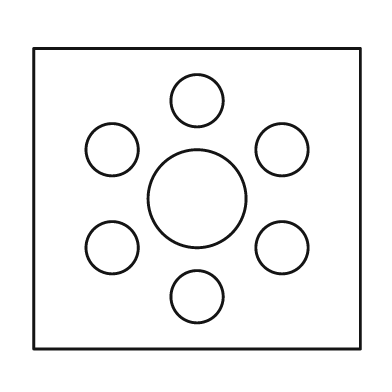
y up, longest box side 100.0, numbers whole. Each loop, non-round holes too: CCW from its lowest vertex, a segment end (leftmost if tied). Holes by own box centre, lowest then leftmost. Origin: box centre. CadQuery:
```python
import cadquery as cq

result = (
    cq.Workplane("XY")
    .moveTo(-50.0, -46.0)
    .lineTo(50.0, -46.0)
    .lineTo(50.0, 46.0)
    .lineTo(-50.0, 46.0)
    .close()
    .moveTo(0.0, -30.0)
    .circle(8.0)
    .moveTo(-26.0, -15.0)
    .circle(8.0)
    .moveTo(26.0, -15.0)
    .circle(8.0)
    .moveTo(0.0, 0.0)
    .circle(15.0)
    .moveTo(-26.0, 15.0)
    .circle(8.0)
    .moveTo(26.0, 15.0)
    .circle(8.0)
    .moveTo(0.0, 30.0)
    .circle(8.0)
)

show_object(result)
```